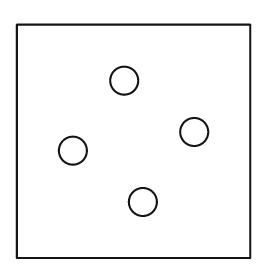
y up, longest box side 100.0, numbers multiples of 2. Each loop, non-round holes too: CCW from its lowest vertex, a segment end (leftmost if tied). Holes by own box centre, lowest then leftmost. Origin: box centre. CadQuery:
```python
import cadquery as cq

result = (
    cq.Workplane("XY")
    .moveTo(-50.0, -50.0)
    .lineTo(50.0, -50.0)
    .lineTo(50.0, 50.0)
    .lineTo(-50.0, 50.0)
    .close()
    .moveTo(4.0, -26.0)
    .circle(6.0)
    .moveTo(-26.0, -4.0)
    .circle(6.0)
    .moveTo(26.0, 4.0)
    .circle(6.0)
    .moveTo(-4.0, 26.0)
    .circle(6.0)
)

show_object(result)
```